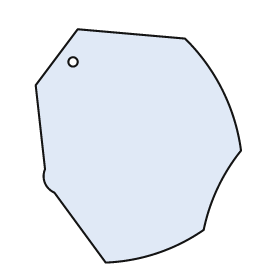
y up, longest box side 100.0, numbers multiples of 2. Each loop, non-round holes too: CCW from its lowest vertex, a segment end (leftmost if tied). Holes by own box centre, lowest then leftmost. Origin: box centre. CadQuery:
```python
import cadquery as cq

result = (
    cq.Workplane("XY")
    .moveTo(-14.0, -50.0)
    .threePointArc((8.0, -46.0), (28.0, -36.0))
    .threePointArc((34.0, -18.0), (44.0, -2.0))
    .threePointArc((36.0, 24.0), (20.0, 46.0))
    .lineTo(-26.0, 50.0)
    .lineTo(-44.0, 26.0)
    .lineTo(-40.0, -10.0)
    .threePointArc((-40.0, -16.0), (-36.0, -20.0))
    .close()
    .moveTo(-28.0, 36.0)
    .circle(2.0)
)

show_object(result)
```